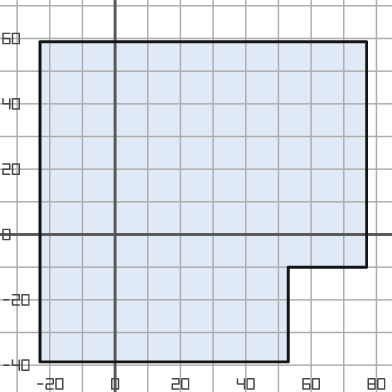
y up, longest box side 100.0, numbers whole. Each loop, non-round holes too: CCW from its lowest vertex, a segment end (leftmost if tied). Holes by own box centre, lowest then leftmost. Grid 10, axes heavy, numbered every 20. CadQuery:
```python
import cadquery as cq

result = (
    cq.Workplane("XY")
    .moveTo(-23.0, -39.0)
    .lineTo(53.0, -39.0)
    .lineTo(53.0, -10.0)
    .lineTo(77.0, -10.0)
    .lineTo(77.0, 59.0)
    .lineTo(-23.0, 59.0)
    .close()
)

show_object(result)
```